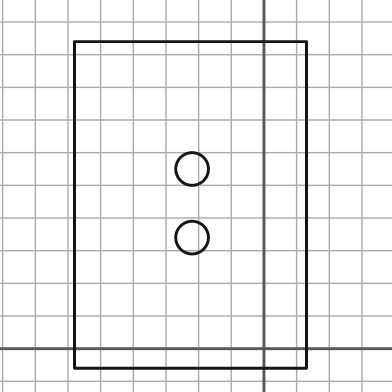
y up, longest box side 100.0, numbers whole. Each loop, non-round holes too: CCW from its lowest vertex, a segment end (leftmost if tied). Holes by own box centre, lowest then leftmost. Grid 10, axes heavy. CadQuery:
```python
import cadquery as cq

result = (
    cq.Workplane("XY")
    .moveTo(-58.0, -6.0)
    .lineTo(13.0, -6.0)
    .lineTo(13.0, 94.0)
    .lineTo(-58.0, 94.0)
    .close()
    .moveTo(-22.0, 34.0)
    .circle(5.0)
    .moveTo(-22.0, 55.0)
    .circle(5.0)
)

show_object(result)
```